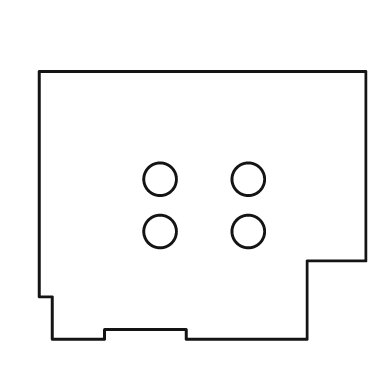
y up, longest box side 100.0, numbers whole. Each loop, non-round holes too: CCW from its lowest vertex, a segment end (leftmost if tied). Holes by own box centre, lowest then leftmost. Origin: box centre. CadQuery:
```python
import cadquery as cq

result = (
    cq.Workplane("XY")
    .moveTo(-46.0, -41.0)
    .lineTo(-30.0, -41.0)
    .lineTo(-30.0, -38.0)
    .lineTo(-5.0, -38.0)
    .lineTo(-5.0, -41.0)
    .lineTo(32.0, -41.0)
    .lineTo(32.0, -17.0)
    .lineTo(50.0, -17.0)
    .lineTo(50.0, 41.0)
    .lineTo(-50.0, 41.0)
    .lineTo(-50.0, -28.0)
    .lineTo(-46.0, -28.0)
    .close()
    .moveTo(-13.0, -8.0)
    .circle(5.0)
    .moveTo(14.0, -8.0)
    .circle(5.0)
    .moveTo(-13.0, 8.0)
    .circle(5.0)
    .moveTo(14.0, 8.0)
    .circle(5.0)
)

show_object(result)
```